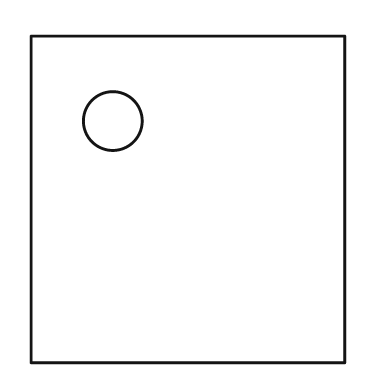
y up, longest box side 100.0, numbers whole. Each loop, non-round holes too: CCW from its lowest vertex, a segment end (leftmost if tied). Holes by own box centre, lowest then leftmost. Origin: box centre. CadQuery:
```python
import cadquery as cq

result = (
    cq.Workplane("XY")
    .moveTo(-48.0, -50.0)
    .lineTo(48.0, -50.0)
    .lineTo(48.0, 50.0)
    .lineTo(-48.0, 50.0)
    .close()
    .moveTo(-23.0, 24.0)
    .circle(9.0)
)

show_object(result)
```